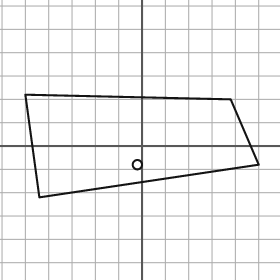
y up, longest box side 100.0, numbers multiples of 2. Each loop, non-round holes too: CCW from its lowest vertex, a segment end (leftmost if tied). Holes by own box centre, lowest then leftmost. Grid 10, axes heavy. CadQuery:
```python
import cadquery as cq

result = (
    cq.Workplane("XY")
    .moveTo(-44.0, -22.0)
    .lineTo(50.0, -8.0)
    .lineTo(38.0, 20.0)
    .lineTo(-50.0, 22.0)
    .close()
    .moveTo(-2.0, -8.0)
    .circle(2.0)
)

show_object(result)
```